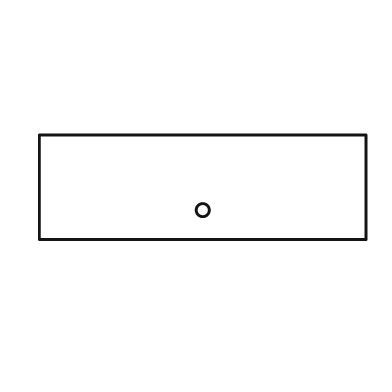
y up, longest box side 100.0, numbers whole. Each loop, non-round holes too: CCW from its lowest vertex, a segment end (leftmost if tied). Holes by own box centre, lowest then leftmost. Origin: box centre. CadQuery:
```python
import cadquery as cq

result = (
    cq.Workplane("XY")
    .moveTo(-50.0, -16.0)
    .lineTo(50.0, -16.0)
    .lineTo(50.0, 16.0)
    .lineTo(-50.0, 16.0)
    .close()
    .moveTo(0.0, -7.0)
    .circle(2.0)
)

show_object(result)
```